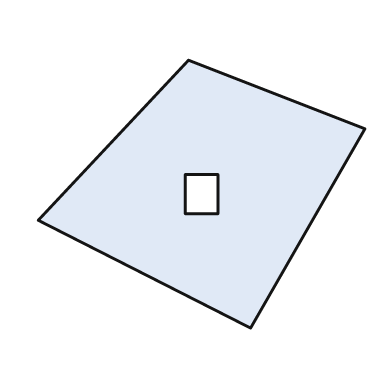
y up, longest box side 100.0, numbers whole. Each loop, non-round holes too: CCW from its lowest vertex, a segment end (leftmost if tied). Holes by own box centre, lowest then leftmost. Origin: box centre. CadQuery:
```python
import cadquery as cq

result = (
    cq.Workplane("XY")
    .moveTo(15.0, -41.0)
    .lineTo(50.0, 20.0)
    .lineTo(-4.0, 41.0)
    .lineTo(-50.0, -8.0)
    .close()
    .moveTo(-5.0, -6.0)
    .lineTo(5.0, -6.0)
    .lineTo(5.0, 6.0)
    .lineTo(-5.0, 6.0)
    .close()
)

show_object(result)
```